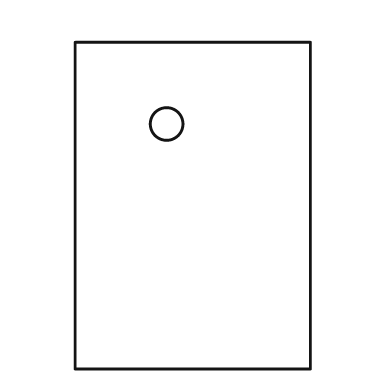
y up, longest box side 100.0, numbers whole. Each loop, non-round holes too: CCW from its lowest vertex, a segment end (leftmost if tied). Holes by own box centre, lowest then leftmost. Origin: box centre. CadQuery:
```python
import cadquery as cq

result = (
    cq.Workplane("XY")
    .moveTo(-36.0, -50.0)
    .lineTo(36.0, -50.0)
    .lineTo(36.0, 50.0)
    .lineTo(-36.0, 50.0)
    .close()
    .moveTo(-8.0, 25.0)
    .circle(5.0)
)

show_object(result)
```